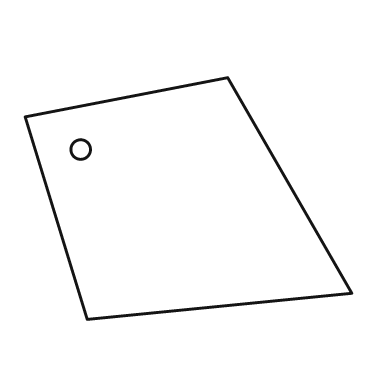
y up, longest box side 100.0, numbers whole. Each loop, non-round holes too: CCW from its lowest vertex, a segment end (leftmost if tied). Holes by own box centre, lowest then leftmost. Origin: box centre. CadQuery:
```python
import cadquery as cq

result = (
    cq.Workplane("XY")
    .moveTo(-31.0, -37.0)
    .lineTo(50.0, -29.0)
    .lineTo(12.0, 37.0)
    .lineTo(-50.0, 25.0)
    .close()
    .moveTo(-33.0, 15.0)
    .circle(3.0)
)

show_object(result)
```